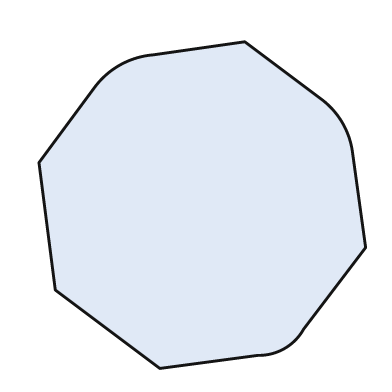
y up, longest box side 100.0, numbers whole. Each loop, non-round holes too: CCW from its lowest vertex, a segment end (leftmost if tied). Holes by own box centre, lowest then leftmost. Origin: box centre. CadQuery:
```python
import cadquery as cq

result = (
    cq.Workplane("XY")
    .moveTo(-13.0, -50.0)
    .lineTo(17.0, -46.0)
    .threePointArc((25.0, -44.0), (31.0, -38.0))
    .lineTo(50.0, -13.0)
    .lineTo(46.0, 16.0)
    .threePointArc((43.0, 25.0), (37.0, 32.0))
    .lineTo(13.0, 50.0)
    .lineTo(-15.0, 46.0)
    .threePointArc((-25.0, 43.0), (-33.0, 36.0))
    .lineTo(-50.0, 13.0)
    .lineTo(-45.0, -26.0)
    .close()
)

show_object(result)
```